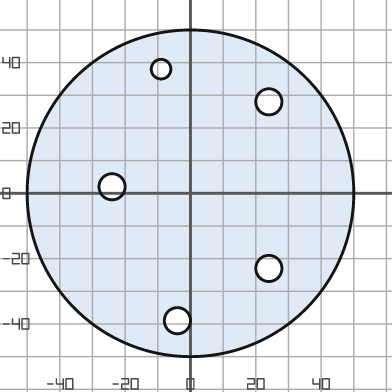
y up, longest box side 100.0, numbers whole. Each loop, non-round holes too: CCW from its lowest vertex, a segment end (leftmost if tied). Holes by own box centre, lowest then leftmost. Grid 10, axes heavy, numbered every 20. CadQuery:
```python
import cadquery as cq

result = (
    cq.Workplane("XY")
    .moveTo(0.0, 0.0)
    .circle(50.0)
    .moveTo(-4.0, -39.0)
    .circle(4.0)
    .moveTo(24.0, -23.0)
    .circle(4.0)
    .moveTo(-24.0, 2.0)
    .circle(4.0)
    .moveTo(24.0, 28.0)
    .circle(4.0)
    .moveTo(-9.0, 38.0)
    .circle(3.0)
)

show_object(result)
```